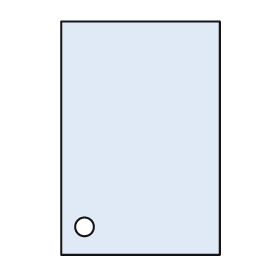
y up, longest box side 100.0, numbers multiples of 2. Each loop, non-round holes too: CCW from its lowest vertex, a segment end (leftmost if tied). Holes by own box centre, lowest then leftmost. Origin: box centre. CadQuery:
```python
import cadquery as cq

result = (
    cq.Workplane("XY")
    .moveTo(-34.0, -50.0)
    .lineTo(34.0, -50.0)
    .lineTo(34.0, 50.0)
    .lineTo(-34.0, 50.0)
    .close()
    .moveTo(-24.0, -38.0)
    .circle(4.0)
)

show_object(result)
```